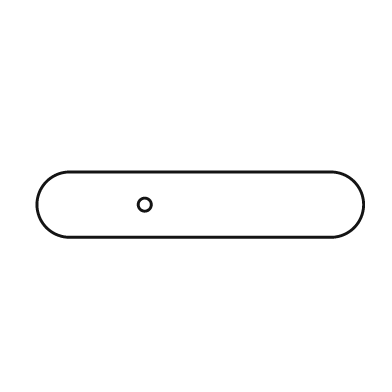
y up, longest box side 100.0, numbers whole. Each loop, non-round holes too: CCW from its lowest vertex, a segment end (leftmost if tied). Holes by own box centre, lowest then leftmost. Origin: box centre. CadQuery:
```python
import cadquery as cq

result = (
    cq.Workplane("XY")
    .moveTo(-40.0, -10.0)
    .lineTo(40.0, -10.0)
    .threePointArc((50.0, 0.0), (40.0, 10.0))
    .lineTo(-40.0, 10.0)
    .threePointArc((-50.0, 0.0), (-40.0, -10.0))
    .close()
    .moveTo(-17.0, 0.0)
    .circle(2.0)
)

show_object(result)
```